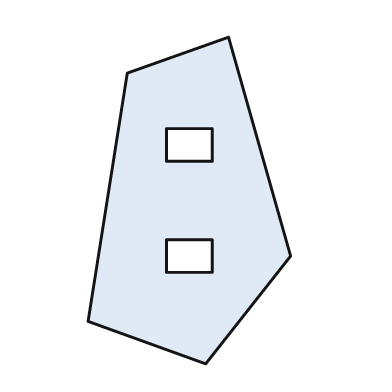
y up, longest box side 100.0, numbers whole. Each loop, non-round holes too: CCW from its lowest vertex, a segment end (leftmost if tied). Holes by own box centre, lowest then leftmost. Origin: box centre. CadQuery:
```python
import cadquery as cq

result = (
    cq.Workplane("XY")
    .moveTo(5.0, -50.0)
    .lineTo(31.0, -17.0)
    .lineTo(12.0, 50.0)
    .lineTo(-19.0, 39.0)
    .lineTo(-31.0, -37.0)
    .close()
    .moveTo(-7.0, -22.0)
    .lineTo(7.0, -22.0)
    .lineTo(7.0, -12.0)
    .lineTo(-7.0, -12.0)
    .close()
    .moveTo(-7.0, 12.0)
    .lineTo(7.0, 12.0)
    .lineTo(7.0, 22.0)
    .lineTo(-7.0, 22.0)
    .close()
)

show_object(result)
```